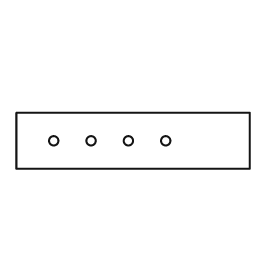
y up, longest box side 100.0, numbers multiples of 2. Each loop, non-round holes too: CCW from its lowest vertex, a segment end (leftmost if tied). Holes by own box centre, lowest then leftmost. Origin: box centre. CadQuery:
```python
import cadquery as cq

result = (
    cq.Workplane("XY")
    .moveTo(-50.0, -12.0)
    .lineTo(50.0, -12.0)
    .lineTo(50.0, 12.0)
    .lineTo(-50.0, 12.0)
    .close()
    .moveTo(-34.0, 0.0)
    .circle(2.0)
    .moveTo(-18.0, 0.0)
    .circle(2.0)
    .moveTo(-2.0, 0.0)
    .circle(2.0)
    .moveTo(14.0, 0.0)
    .circle(2.0)
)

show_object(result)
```